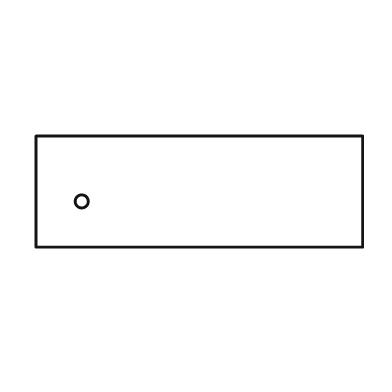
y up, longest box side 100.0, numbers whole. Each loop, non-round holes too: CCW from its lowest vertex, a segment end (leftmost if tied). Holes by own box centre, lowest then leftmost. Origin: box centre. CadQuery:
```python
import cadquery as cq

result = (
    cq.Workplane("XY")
    .moveTo(-50.0, -17.0)
    .lineTo(50.0, -17.0)
    .lineTo(50.0, 17.0)
    .lineTo(-50.0, 17.0)
    .close()
    .moveTo(-36.0, -3.0)
    .circle(2.0)
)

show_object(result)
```